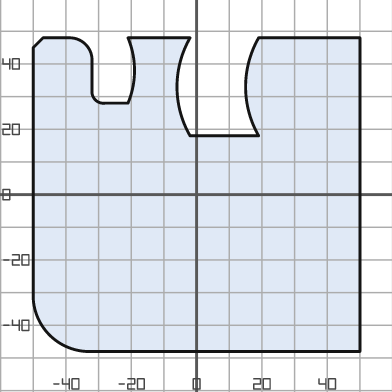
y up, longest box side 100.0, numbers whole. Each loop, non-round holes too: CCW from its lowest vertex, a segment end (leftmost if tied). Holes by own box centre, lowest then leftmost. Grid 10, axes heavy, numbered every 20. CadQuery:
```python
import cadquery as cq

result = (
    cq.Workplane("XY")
    .moveTo(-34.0, -48.0)
    .lineTo(50.0, -48.0)
    .lineTo(50.0, 48.0)
    .lineTo(19.0, 48.0)
    .threePointArc((15.0, 33.0), (19.0, 18.0))
    .lineTo(-2.0, 18.0)
    .threePointArc((-6.0, 33.0), (-2.0, 48.0))
    .lineTo(-21.0, 48.0)
    .threePointArc((-19.0, 38.0), (-21.0, 28.0))
    .lineTo(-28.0, 28.0)
    .threePointArc((-31.0, 29.0), (-32.0, 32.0))
    .lineTo(-32.0, 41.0)
    .threePointArc((-34.0, 46.0), (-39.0, 48.0))
    .lineTo(-47.0, 48.0)
    .lineTo(-50.0, 45.0)
    .lineTo(-50.0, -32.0)
    .threePointArc((-45.0, -43.0), (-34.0, -48.0))
    .close()
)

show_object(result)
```